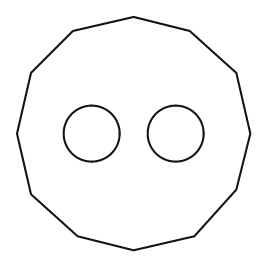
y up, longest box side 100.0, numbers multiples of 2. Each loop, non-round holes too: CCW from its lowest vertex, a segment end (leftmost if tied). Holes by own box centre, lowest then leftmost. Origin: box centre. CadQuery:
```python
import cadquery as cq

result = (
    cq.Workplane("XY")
    .moveTo(0.0, -50.0)
    .lineTo(26.0, -44.0)
    .lineTo(44.0, -24.0)
    .lineTo(50.0, 0.0)
    .lineTo(44.0, 26.0)
    .lineTo(24.0, 44.0)
    .lineTo(0.0, 50.0)
    .lineTo(-26.0, 44.0)
    .lineTo(-44.0, 26.0)
    .lineTo(-50.0, 0.0)
    .lineTo(-44.0, -26.0)
    .lineTo(-24.0, -44.0)
    .close()
    .moveTo(-18.0, 0.0)
    .circle(12.0)
    .moveTo(18.0, 0.0)
    .circle(12.0)
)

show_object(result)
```